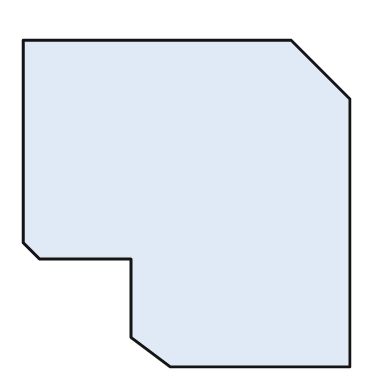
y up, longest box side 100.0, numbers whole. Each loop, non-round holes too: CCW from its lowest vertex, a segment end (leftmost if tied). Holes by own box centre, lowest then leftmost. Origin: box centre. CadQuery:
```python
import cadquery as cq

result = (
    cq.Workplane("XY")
    .moveTo(-5.0, -50.0)
    .lineTo(50.0, -50.0)
    .lineTo(50.0, 32.0)
    .lineTo(32.0, 50.0)
    .lineTo(-50.0, 50.0)
    .lineTo(-50.0, -12.0)
    .lineTo(-45.0, -17.0)
    .lineTo(-17.0, -17.0)
    .lineTo(-17.0, -41.0)
    .close()
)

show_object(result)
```